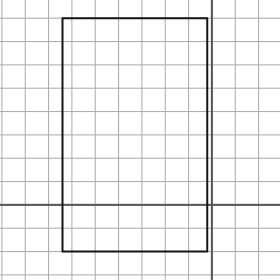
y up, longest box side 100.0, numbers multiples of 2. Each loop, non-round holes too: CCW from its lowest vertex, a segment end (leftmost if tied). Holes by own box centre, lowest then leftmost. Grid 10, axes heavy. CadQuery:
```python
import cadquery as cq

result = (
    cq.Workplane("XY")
    .moveTo(-64.0, -20.0)
    .lineTo(-2.0, -20.0)
    .lineTo(-2.0, 80.0)
    .lineTo(-64.0, 80.0)
    .close()
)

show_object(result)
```